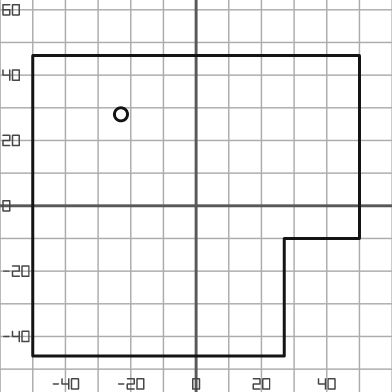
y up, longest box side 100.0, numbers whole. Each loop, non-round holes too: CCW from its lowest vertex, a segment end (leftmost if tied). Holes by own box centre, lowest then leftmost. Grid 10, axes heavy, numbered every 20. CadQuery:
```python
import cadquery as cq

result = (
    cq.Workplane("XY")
    .moveTo(-50.0, -46.0)
    .lineTo(27.0, -46.0)
    .lineTo(27.0, -10.0)
    .lineTo(50.0, -10.0)
    .lineTo(50.0, 46.0)
    .lineTo(-50.0, 46.0)
    .close()
    .moveTo(-23.0, 28.0)
    .circle(2.0)
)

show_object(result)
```